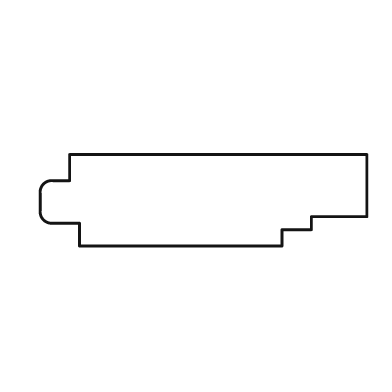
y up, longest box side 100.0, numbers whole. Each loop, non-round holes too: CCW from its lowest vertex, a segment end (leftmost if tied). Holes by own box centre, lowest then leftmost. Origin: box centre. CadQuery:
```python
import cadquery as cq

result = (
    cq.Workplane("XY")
    .moveTo(-38.0, -14.0)
    .lineTo(24.0, -14.0)
    .lineTo(24.0, -9.0)
    .lineTo(33.0, -9.0)
    .lineTo(33.0, -5.0)
    .lineTo(50.0, -5.0)
    .lineTo(50.0, 14.0)
    .lineTo(-41.0, 14.0)
    .lineTo(-41.0, 6.0)
    .lineTo(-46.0, 6.0)
    .threePointArc((-49.0, 5.0), (-50.0, 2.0))
    .lineTo(-50.0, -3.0)
    .threePointArc((-49.0, -6.0), (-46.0, -7.0))
    .lineTo(-38.0, -7.0)
    .close()
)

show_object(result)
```